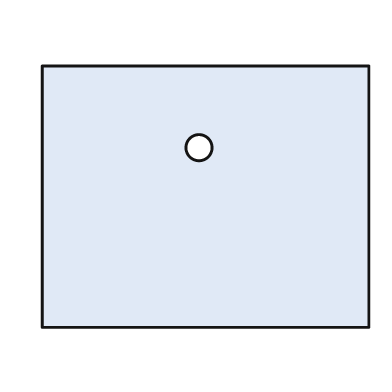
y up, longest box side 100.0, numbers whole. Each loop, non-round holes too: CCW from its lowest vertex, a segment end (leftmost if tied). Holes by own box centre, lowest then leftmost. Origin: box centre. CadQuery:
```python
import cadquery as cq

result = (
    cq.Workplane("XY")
    .moveTo(-50.0, -40.0)
    .lineTo(50.0, -40.0)
    .lineTo(50.0, 40.0)
    .lineTo(-50.0, 40.0)
    .close()
    .moveTo(-2.0, 15.0)
    .circle(4.0)
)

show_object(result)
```